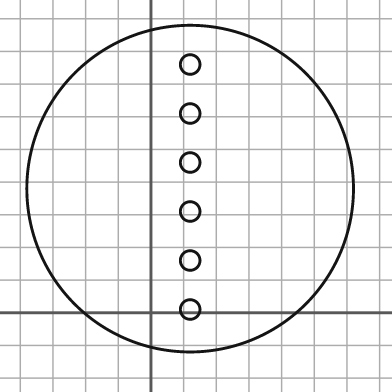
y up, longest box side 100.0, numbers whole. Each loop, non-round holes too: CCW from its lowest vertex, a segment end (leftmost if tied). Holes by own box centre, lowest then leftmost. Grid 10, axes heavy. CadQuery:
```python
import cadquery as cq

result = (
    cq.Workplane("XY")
    .moveTo(12.0, 38.0)
    .circle(50.0)
    .moveTo(12.0, 1.0)
    .circle(3.0)
    .moveTo(12.0, 16.0)
    .circle(3.0)
    .moveTo(12.0, 31.0)
    .circle(3.0)
    .moveTo(12.0, 46.0)
    .circle(3.0)
    .moveTo(12.0, 61.0)
    .circle(3.0)
    .moveTo(12.0, 76.0)
    .circle(3.0)
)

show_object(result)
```